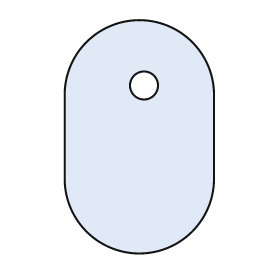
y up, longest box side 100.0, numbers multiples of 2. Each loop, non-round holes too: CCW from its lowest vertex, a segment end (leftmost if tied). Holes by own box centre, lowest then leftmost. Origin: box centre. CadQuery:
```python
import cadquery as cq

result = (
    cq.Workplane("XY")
    .moveTo(-32.0, -18.0)
    .threePointArc((0.0, -50.0), (32.0, -18.0))
    .lineTo(32.0, 18.0)
    .threePointArc((0.0, 50.0), (-32.0, 18.0))
    .close()
    .moveTo(2.0, 22.0)
    .circle(6.0)
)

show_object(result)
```